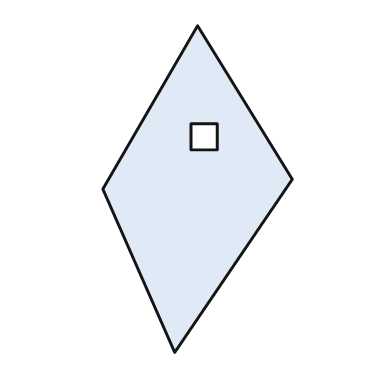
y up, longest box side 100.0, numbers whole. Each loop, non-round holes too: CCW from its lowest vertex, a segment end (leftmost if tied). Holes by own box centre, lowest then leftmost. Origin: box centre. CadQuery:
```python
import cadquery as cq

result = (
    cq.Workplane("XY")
    .moveTo(-7.0, -50.0)
    .lineTo(29.0, 3.0)
    .lineTo(0.0, 50.0)
    .lineTo(-29.0, 0.0)
    .close()
    .moveTo(-2.0, 12.0)
    .lineTo(6.0, 12.0)
    .lineTo(6.0, 20.0)
    .lineTo(-2.0, 20.0)
    .close()
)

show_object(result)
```